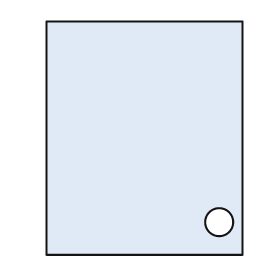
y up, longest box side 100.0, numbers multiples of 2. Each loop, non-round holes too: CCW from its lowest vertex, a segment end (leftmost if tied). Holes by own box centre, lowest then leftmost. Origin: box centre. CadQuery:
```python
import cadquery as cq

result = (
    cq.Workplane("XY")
    .moveTo(-42.0, -50.0)
    .lineTo(42.0, -50.0)
    .lineTo(42.0, 50.0)
    .lineTo(-42.0, 50.0)
    .close()
    .moveTo(32.0, -36.0)
    .circle(6.0)
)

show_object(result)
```